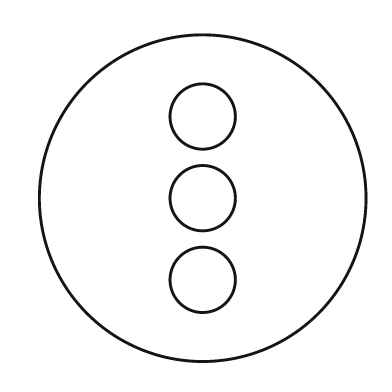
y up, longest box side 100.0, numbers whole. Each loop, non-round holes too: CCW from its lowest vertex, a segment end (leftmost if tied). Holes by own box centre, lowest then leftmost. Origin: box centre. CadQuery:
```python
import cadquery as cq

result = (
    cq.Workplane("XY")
    .moveTo(0.0, 0.0)
    .circle(50.0)
    .moveTo(0.0, -25.0)
    .circle(10.0)
    .moveTo(0.0, 0.0)
    .circle(10.0)
    .moveTo(0.0, 25.0)
    .circle(10.0)
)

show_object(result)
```